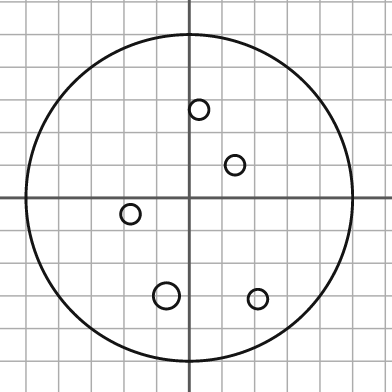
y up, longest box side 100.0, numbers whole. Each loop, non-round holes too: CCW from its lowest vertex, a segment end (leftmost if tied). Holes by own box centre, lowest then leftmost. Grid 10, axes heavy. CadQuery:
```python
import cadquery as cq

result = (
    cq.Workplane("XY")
    .moveTo(0.0, 0.0)
    .circle(50.0)
    .moveTo(21.0, -31.0)
    .circle(3.0)
    .moveTo(-7.0, -30.0)
    .circle(4.0)
    .moveTo(-18.0, -5.0)
    .circle(3.0)
    .moveTo(14.0, 10.0)
    .circle(3.0)
    .moveTo(3.0, 27.0)
    .circle(3.0)
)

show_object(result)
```